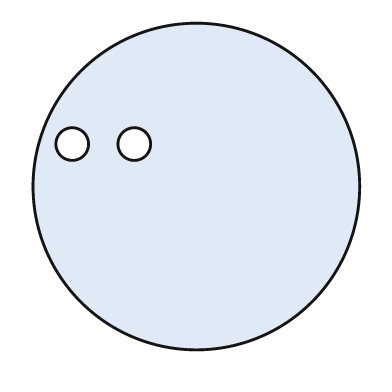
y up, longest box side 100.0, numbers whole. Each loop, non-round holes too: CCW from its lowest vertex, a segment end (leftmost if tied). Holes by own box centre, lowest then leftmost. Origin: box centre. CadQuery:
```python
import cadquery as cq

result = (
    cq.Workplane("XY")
    .moveTo(0.0, 0.0)
    .circle(50.0)
    .moveTo(-38.0, 13.0)
    .circle(5.0)
    .moveTo(-19.0, 13.0)
    .circle(5.0)
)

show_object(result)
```